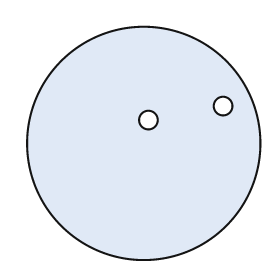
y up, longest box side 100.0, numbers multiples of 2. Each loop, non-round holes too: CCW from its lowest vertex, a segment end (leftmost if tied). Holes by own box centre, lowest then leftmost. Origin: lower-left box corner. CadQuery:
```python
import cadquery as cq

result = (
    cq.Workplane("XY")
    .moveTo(50.0, 50.0)
    .circle(50.0)
    .moveTo(52.0, 60.0)
    .circle(4.0)
    .moveTo(84.0, 66.0)
    .circle(4.0)
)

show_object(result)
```